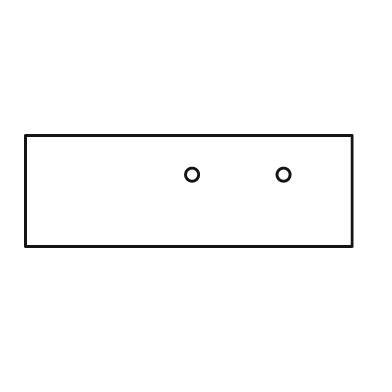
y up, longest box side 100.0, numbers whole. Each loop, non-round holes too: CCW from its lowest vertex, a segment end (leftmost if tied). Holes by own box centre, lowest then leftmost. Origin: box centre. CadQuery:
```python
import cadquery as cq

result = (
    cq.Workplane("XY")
    .moveTo(-50.0, -17.0)
    .lineTo(50.0, -17.0)
    .lineTo(50.0, 17.0)
    .lineTo(-50.0, 17.0)
    .close()
    .moveTo(1.0, 5.0)
    .circle(2.0)
    .moveTo(29.0, 5.0)
    .circle(2.0)
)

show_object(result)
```